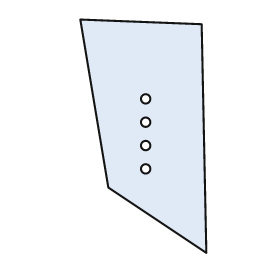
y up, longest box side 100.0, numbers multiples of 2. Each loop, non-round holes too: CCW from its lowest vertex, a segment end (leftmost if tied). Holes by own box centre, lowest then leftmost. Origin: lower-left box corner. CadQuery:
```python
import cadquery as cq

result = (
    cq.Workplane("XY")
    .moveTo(54.0, 0.0)
    .lineTo(52.0, 98.0)
    .lineTo(0.0, 100.0)
    .lineTo(12.0, 28.0)
    .close()
    .moveTo(28.0, 36.0)
    .circle(2.0)
    .moveTo(28.0, 46.0)
    .circle(2.0)
    .moveTo(28.0, 56.0)
    .circle(2.0)
    .moveTo(28.0, 66.0)
    .circle(2.0)
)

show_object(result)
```